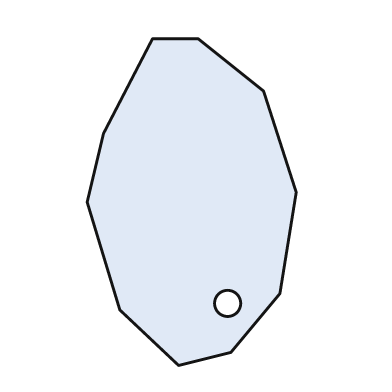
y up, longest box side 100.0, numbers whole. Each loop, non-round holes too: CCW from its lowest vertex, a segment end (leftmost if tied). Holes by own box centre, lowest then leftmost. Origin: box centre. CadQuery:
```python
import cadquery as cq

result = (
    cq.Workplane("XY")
    .moveTo(-4.0, -50.0)
    .lineTo(12.0, -46.0)
    .lineTo(27.0, -28.0)
    .lineTo(32.0, 3.0)
    .lineTo(22.0, 34.0)
    .lineTo(2.0, 50.0)
    .lineTo(-12.0, 50.0)
    .lineTo(-27.0, 21.0)
    .lineTo(-32.0, 0.0)
    .lineTo(-22.0, -33.0)
    .close()
    .moveTo(11.0, -31.0)
    .circle(4.0)
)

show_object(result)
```